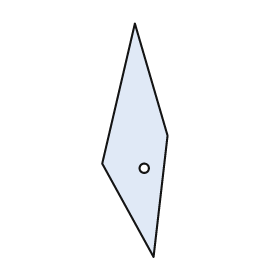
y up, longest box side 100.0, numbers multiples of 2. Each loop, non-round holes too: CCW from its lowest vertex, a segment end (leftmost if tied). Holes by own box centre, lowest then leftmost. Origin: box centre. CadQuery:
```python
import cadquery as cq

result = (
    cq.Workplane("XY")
    .moveTo(8.0, -50.0)
    .lineTo(14.0, 2.0)
    .lineTo(0.0, 50.0)
    .lineTo(-14.0, -10.0)
    .close()
    .moveTo(4.0, -12.0)
    .circle(2.0)
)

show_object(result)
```